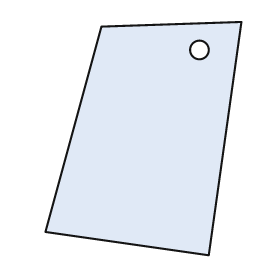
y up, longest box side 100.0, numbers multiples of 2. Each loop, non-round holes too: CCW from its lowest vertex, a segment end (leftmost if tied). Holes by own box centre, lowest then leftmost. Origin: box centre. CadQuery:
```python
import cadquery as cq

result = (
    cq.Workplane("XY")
    .moveTo(28.0, -50.0)
    .lineTo(42.0, 50.0)
    .lineTo(-18.0, 48.0)
    .lineTo(-42.0, -40.0)
    .close()
    .moveTo(24.0, 38.0)
    .circle(4.0)
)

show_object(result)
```